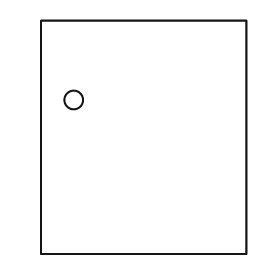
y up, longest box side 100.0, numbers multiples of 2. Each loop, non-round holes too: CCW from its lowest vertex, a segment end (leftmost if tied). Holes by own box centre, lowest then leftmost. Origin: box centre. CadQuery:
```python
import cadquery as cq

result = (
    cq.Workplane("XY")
    .moveTo(-44.0, -50.0)
    .lineTo(44.0, -50.0)
    .lineTo(44.0, 50.0)
    .lineTo(-44.0, 50.0)
    .close()
    .moveTo(-30.0, 16.0)
    .circle(4.0)
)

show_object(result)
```